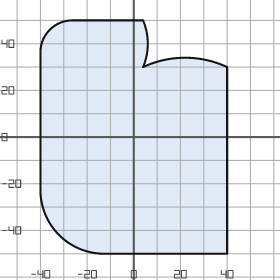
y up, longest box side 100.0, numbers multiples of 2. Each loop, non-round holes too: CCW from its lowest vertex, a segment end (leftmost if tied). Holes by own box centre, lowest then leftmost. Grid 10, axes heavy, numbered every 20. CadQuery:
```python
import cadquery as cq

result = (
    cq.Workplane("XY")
    .moveTo(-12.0, -50.0)
    .lineTo(40.0, -50.0)
    .lineTo(40.0, 30.0)
    .threePointArc((22.0, 34.0), (4.0, 30.0))
    .threePointArc((6.0, 40.0), (4.0, 50.0))
    .lineTo(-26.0, 50.0)
    .threePointArc((-36.0, 46.0), (-40.0, 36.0))
    .lineTo(-40.0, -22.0)
    .threePointArc((-32.0, -42.0), (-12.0, -50.0))
    .close()
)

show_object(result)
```